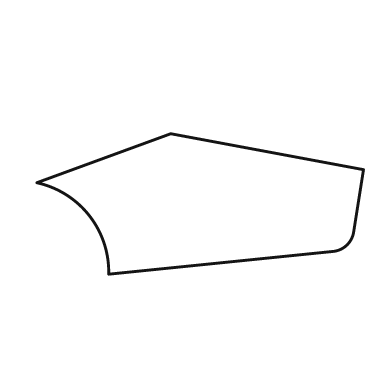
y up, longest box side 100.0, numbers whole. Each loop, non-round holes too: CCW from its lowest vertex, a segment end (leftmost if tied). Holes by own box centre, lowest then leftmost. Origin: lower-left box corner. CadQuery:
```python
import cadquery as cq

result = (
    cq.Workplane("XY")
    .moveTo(22.0, 0.0)
    .lineTo(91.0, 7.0)
    .threePointArc((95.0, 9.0), (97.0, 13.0))
    .lineTo(100.0, 32.0)
    .lineTo(41.0, 43.0)
    .lineTo(0.0, 28.0)
    .threePointArc((16.0, 18.0), (22.0, 0.0))
    .close()
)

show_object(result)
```